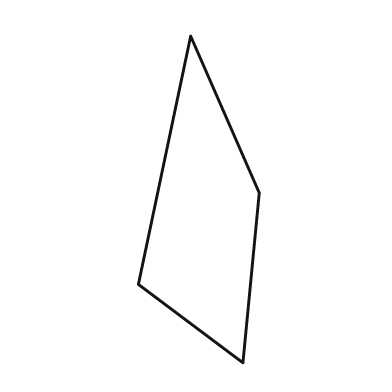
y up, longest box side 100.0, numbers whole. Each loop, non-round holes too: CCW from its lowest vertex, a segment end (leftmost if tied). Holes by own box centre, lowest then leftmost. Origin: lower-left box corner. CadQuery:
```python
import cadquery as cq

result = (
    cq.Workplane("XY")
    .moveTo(32.0, 0.0)
    .lineTo(37.0, 52.0)
    .lineTo(16.0, 100.0)
    .lineTo(0.0, 24.0)
    .close()
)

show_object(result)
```